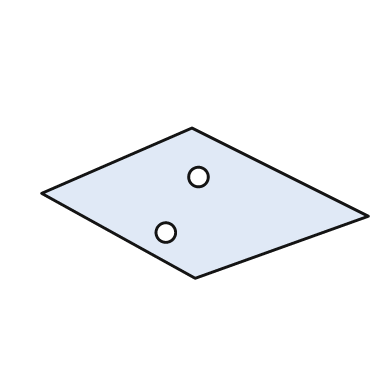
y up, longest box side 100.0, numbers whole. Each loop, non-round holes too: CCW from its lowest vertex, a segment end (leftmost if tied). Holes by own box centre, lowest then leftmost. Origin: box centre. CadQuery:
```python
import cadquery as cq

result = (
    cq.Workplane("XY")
    .moveTo(-3.0, -23.0)
    .lineTo(50.0, -4.0)
    .lineTo(-4.0, 23.0)
    .lineTo(-50.0, 3.0)
    .close()
    .moveTo(-12.0, -9.0)
    .circle(3.0)
    .moveTo(-2.0, 8.0)
    .circle(3.0)
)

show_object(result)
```